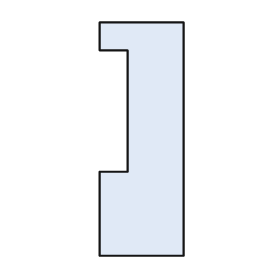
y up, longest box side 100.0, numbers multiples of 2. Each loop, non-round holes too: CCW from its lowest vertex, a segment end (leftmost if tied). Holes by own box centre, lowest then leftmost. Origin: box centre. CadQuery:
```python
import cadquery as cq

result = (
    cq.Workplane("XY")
    .moveTo(-18.0, -50.0)
    .lineTo(18.0, -50.0)
    .lineTo(18.0, 50.0)
    .lineTo(-18.0, 50.0)
    .lineTo(-18.0, 38.0)
    .lineTo(-6.0, 38.0)
    .lineTo(-6.0, -14.0)
    .lineTo(-18.0, -14.0)
    .close()
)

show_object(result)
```